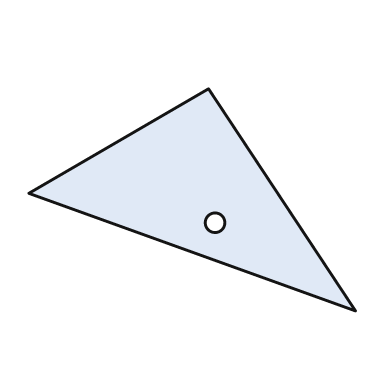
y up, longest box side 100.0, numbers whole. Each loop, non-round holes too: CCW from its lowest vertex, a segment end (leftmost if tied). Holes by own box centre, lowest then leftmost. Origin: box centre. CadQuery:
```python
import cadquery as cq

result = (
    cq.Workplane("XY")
    .moveTo(50.0, -34.0)
    .lineTo(5.0, 34.0)
    .lineTo(-50.0, 2.0)
    .close()
    .moveTo(7.0, -7.0)
    .circle(3.0)
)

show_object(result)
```